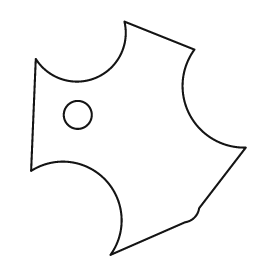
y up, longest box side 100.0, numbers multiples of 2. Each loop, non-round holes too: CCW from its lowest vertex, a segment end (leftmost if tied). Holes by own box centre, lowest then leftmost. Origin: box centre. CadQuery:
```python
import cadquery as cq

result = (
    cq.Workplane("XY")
    .moveTo(-12.0, -50.0)
    .lineTo(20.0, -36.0)
    .threePointArc((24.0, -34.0), (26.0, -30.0))
    .lineTo(46.0, -4.0)
    .threePointArc((22.0, 10.0), (24.0, 38.0))
    .lineTo(-6.0, 50.0)
    .threePointArc((-18.0, 26.0), (-44.0, 34.0))
    .lineTo(-46.0, -14.0)
    .threePointArc((-14.0, -18.0), (-12.0, -50.0))
    .close()
    .moveTo(-26.0, 10.0)
    .circle(6.0)
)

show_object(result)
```